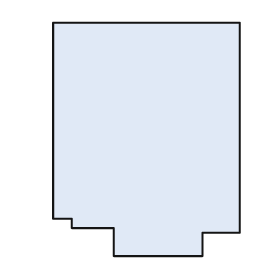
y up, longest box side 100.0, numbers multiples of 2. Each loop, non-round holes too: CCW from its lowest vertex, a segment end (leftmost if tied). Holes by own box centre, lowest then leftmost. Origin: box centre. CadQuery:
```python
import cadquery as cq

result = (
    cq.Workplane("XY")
    .moveTo(-14.0, -50.0)
    .lineTo(24.0, -50.0)
    .lineTo(24.0, -40.0)
    .lineTo(40.0, -40.0)
    .lineTo(40.0, 50.0)
    .lineTo(-40.0, 50.0)
    .lineTo(-40.0, -34.0)
    .lineTo(-32.0, -34.0)
    .lineTo(-32.0, -38.0)
    .lineTo(-14.0, -38.0)
    .close()
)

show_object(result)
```